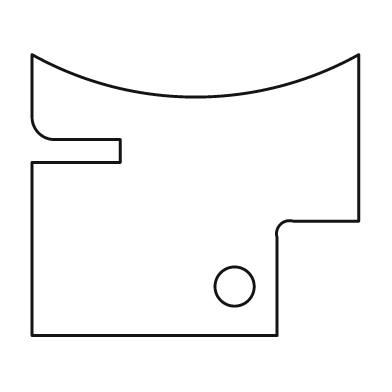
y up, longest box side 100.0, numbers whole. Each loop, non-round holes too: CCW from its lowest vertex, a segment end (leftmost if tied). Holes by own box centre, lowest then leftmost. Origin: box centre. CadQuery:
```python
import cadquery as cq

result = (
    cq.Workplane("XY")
    .moveTo(-50.0, -43.0)
    .lineTo(25.0, -43.0)
    .lineTo(25.0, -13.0)
    .threePointArc((26.0, -9.0), (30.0, -8.0))
    .lineTo(50.0, -8.0)
    .lineTo(50.0, 43.0)
    .threePointArc((0.0, 30.0), (-50.0, 43.0))
    .lineTo(-50.0, 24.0)
    .threePointArc((-48.0, 19.0), (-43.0, 17.0))
    .lineTo(-23.0, 17.0)
    .lineTo(-23.0, 10.0)
    .lineTo(-50.0, 10.0)
    .close()
    .moveTo(12.0, -28.0)
    .circle(6.0)
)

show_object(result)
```